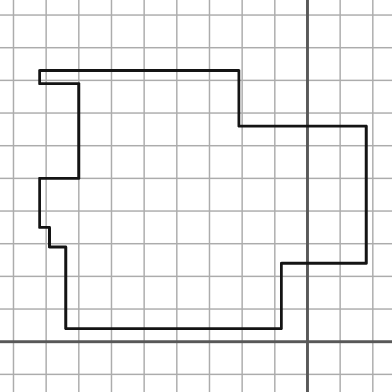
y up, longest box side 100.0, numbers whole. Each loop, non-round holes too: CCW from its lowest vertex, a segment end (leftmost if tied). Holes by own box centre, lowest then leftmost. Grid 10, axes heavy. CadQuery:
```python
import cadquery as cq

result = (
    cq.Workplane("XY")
    .moveTo(-74.0, 4.0)
    .lineTo(-8.0, 4.0)
    .lineTo(-8.0, 24.0)
    .lineTo(18.0, 24.0)
    .lineTo(18.0, 66.0)
    .lineTo(-21.0, 66.0)
    .lineTo(-21.0, 83.0)
    .lineTo(-82.0, 83.0)
    .lineTo(-82.0, 79.0)
    .lineTo(-70.0, 79.0)
    .lineTo(-70.0, 50.0)
    .lineTo(-82.0, 50.0)
    .lineTo(-82.0, 35.0)
    .lineTo(-79.0, 35.0)
    .lineTo(-79.0, 29.0)
    .lineTo(-74.0, 29.0)
    .close()
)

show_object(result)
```